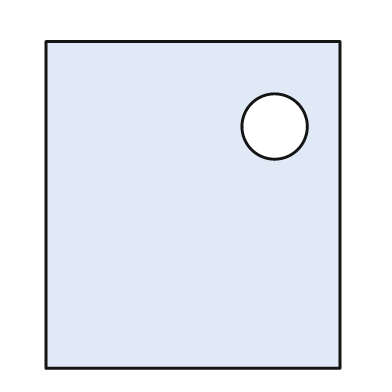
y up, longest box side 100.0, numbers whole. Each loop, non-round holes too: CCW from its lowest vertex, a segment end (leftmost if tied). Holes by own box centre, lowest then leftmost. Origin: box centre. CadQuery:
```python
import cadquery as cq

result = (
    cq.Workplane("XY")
    .moveTo(-45.0, -50.0)
    .lineTo(45.0, -50.0)
    .lineTo(45.0, 50.0)
    .lineTo(-45.0, 50.0)
    .close()
    .moveTo(25.0, 24.0)
    .circle(10.0)
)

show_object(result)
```